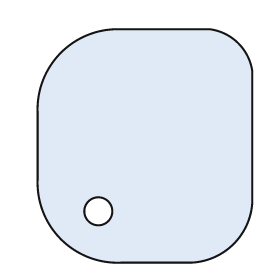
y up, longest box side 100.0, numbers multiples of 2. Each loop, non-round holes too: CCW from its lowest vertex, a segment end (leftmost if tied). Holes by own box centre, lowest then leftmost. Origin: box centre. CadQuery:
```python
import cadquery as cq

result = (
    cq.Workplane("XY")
    .moveTo(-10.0, -50.0)
    .lineTo(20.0, -50.0)
    .threePointArc((38.0, -42.0), (46.0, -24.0))
    .lineTo(46.0, 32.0)
    .threePointArc((40.0, 44.0), (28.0, 50.0))
    .lineTo(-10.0, 50.0)
    .threePointArc((-36.0, 40.0), (-46.0, 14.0))
    .lineTo(-46.0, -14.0)
    .threePointArc((-36.0, -40.0), (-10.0, -50.0))
    .close()
    .moveTo(-20.0, -28.0)
    .circle(6.0)
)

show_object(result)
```